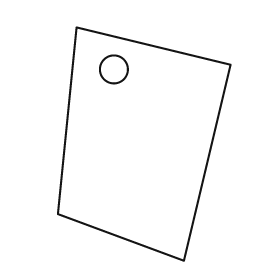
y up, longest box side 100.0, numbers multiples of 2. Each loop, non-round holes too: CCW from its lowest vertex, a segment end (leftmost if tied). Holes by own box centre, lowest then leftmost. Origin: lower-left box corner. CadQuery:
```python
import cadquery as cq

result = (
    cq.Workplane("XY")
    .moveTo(54.0, 0.0)
    .lineTo(74.0, 84.0)
    .lineTo(8.0, 100.0)
    .lineTo(0.0, 20.0)
    .close()
    .moveTo(24.0, 82.0)
    .circle(6.0)
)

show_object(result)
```